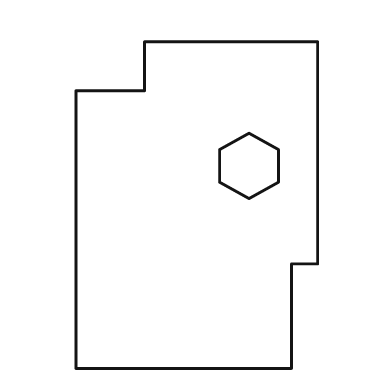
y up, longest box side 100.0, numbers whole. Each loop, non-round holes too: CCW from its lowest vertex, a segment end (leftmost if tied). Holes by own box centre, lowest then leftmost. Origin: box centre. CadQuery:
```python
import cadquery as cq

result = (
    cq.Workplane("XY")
    .moveTo(-37.0, -50.0)
    .lineTo(29.0, -50.0)
    .lineTo(29.0, -18.0)
    .lineTo(37.0, -18.0)
    .lineTo(37.0, 50.0)
    .lineTo(-16.0, 50.0)
    .lineTo(-16.0, 35.0)
    .lineTo(-37.0, 35.0)
    .close()
    .moveTo(16.0, 2.0)
    .lineTo(25.0, 7.0)
    .lineTo(25.0, 17.0)
    .lineTo(16.0, 22.0)
    .lineTo(7.0, 17.0)
    .lineTo(7.0, 7.0)
    .close()
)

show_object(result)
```